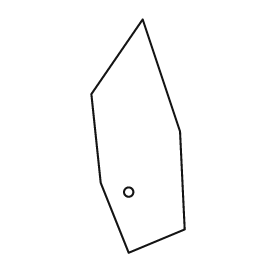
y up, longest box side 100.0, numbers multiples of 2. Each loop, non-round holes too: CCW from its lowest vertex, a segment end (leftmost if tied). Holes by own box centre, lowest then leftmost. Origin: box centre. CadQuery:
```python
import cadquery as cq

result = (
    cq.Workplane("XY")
    .moveTo(-4.0, -50.0)
    .lineTo(20.0, -40.0)
    .lineTo(18.0, 2.0)
    .lineTo(2.0, 50.0)
    .lineTo(-20.0, 18.0)
    .lineTo(-16.0, -20.0)
    .close()
    .moveTo(-4.0, -24.0)
    .circle(2.0)
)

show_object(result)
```